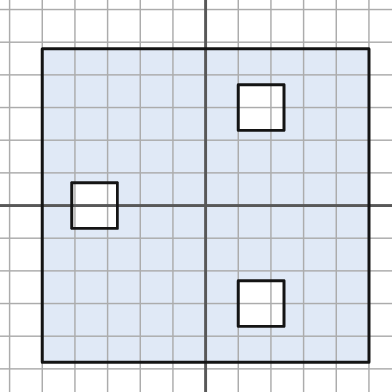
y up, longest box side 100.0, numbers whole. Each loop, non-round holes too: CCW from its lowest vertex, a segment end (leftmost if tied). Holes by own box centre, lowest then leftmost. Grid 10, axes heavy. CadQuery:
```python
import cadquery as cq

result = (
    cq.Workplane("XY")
    .moveTo(-50.0, -48.0)
    .lineTo(50.0, -48.0)
    .lineTo(50.0, 48.0)
    .lineTo(-50.0, 48.0)
    .close()
    .moveTo(10.0, -37.0)
    .lineTo(24.0, -37.0)
    .lineTo(24.0, -23.0)
    .lineTo(10.0, -23.0)
    .close()
    .moveTo(-41.0, -7.0)
    .lineTo(-27.0, -7.0)
    .lineTo(-27.0, 7.0)
    .lineTo(-41.0, 7.0)
    .close()
    .moveTo(10.0, 23.0)
    .lineTo(24.0, 23.0)
    .lineTo(24.0, 37.0)
    .lineTo(10.0, 37.0)
    .close()
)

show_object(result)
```